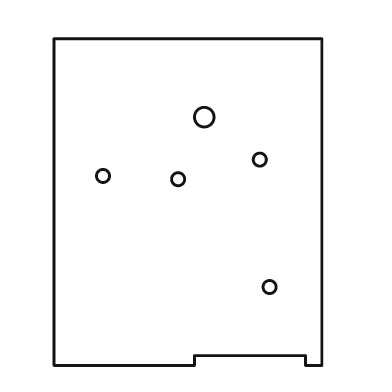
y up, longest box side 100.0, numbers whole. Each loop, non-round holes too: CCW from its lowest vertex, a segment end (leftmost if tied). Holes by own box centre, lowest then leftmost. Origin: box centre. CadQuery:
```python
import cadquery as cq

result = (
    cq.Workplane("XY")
    .moveTo(-41.0, -50.0)
    .lineTo(2.0, -50.0)
    .lineTo(2.0, -47.0)
    .lineTo(36.0, -47.0)
    .lineTo(36.0, -50.0)
    .lineTo(41.0, -50.0)
    .lineTo(41.0, 50.0)
    .lineTo(-41.0, 50.0)
    .close()
    .moveTo(25.0, -26.0)
    .circle(2.0)
    .moveTo(-3.0, 7.0)
    .circle(2.0)
    .moveTo(-26.0, 8.0)
    .circle(2.0)
    .moveTo(22.0, 13.0)
    .circle(2.0)
    .moveTo(5.0, 26.0)
    .circle(3.0)
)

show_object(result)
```